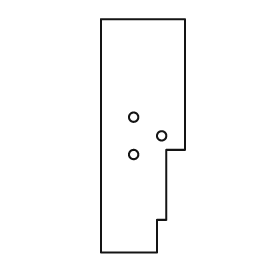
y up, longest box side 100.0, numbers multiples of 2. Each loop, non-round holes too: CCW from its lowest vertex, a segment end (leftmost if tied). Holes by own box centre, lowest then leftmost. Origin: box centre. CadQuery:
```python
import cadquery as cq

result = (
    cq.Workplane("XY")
    .moveTo(-18.0, -50.0)
    .lineTo(6.0, -50.0)
    .lineTo(6.0, -36.0)
    .lineTo(10.0, -36.0)
    .lineTo(10.0, -6.0)
    .lineTo(18.0, -6.0)
    .lineTo(18.0, 50.0)
    .lineTo(-18.0, 50.0)
    .close()
    .moveTo(-4.0, -8.0)
    .circle(2.0)
    .moveTo(8.0, 0.0)
    .circle(2.0)
    .moveTo(-4.0, 8.0)
    .circle(2.0)
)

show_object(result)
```